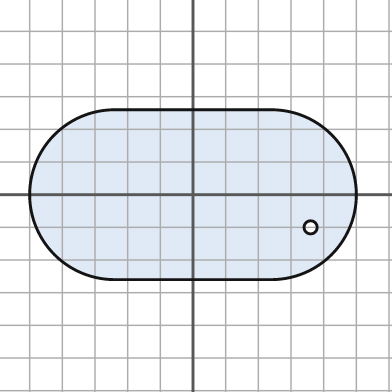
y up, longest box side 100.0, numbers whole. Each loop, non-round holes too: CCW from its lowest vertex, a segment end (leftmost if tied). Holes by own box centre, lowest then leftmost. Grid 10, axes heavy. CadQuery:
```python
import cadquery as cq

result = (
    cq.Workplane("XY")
    .moveTo(-24.0, -26.0)
    .lineTo(24.0, -26.0)
    .threePointArc((50.0, 0.0), (24.0, 26.0))
    .lineTo(-24.0, 26.0)
    .threePointArc((-50.0, 0.0), (-24.0, -26.0))
    .close()
    .moveTo(36.0, -10.0)
    .circle(2.0)
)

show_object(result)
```